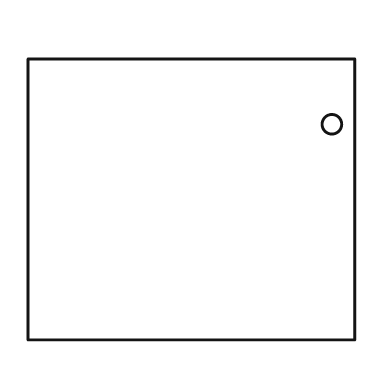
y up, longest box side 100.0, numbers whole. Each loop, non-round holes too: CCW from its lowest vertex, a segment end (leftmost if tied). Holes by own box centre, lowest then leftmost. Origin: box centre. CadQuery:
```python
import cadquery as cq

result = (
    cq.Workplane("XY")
    .moveTo(-50.0, -43.0)
    .lineTo(50.0, -43.0)
    .lineTo(50.0, 43.0)
    .lineTo(-50.0, 43.0)
    .close()
    .moveTo(43.0, 23.0)
    .circle(3.0)
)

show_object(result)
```